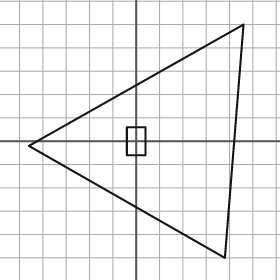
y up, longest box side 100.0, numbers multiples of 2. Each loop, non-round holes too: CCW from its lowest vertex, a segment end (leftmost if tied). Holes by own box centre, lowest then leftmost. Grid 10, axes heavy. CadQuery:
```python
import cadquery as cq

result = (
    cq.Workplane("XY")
    .moveTo(38.0, -50.0)
    .lineTo(46.0, 50.0)
    .lineTo(-46.0, -2.0)
    .close()
    .moveTo(-4.0, -6.0)
    .lineTo(4.0, -6.0)
    .lineTo(4.0, 6.0)
    .lineTo(-4.0, 6.0)
    .close()
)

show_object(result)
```